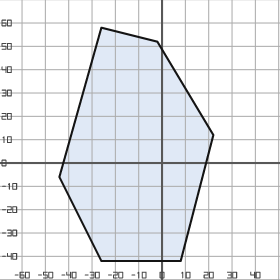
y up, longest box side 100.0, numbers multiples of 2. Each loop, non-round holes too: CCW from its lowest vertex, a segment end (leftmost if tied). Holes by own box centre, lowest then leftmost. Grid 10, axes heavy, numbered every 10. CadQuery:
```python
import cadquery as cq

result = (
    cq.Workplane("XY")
    .moveTo(-26.0, -42.0)
    .lineTo(8.0, -42.0)
    .lineTo(22.0, 12.0)
    .lineTo(-2.0, 52.0)
    .lineTo(-26.0, 58.0)
    .lineTo(-44.0, -6.0)
    .close()
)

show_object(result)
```